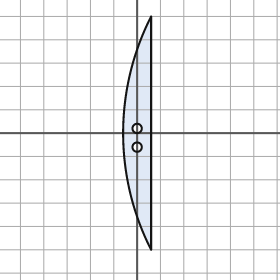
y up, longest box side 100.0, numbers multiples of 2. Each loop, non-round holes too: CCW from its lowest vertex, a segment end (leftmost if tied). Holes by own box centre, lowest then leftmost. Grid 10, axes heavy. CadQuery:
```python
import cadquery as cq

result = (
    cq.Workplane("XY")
    .moveTo(6.0, -50.0)
    .lineTo(6.0, 50.0)
    .threePointArc((-6.0, 0.0), (6.0, -50.0))
    .close()
    .moveTo(0.0, -6.0)
    .circle(2.0)
    .moveTo(0.0, 2.0)
    .circle(2.0)
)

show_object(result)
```